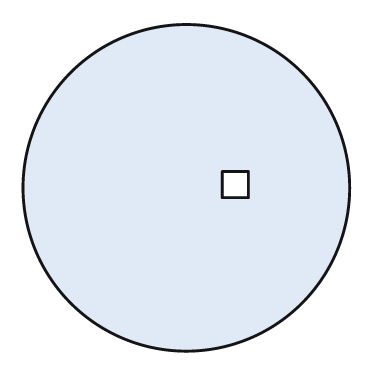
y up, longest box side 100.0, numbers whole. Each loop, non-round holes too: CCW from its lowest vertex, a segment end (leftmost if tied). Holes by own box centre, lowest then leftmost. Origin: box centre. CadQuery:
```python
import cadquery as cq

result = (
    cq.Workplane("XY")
    .moveTo(0.0, 0.0)
    .circle(50.0)
    .moveTo(11.0, -3.0)
    .lineTo(19.0, -3.0)
    .lineTo(19.0, 5.0)
    .lineTo(11.0, 5.0)
    .close()
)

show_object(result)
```